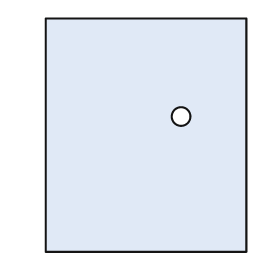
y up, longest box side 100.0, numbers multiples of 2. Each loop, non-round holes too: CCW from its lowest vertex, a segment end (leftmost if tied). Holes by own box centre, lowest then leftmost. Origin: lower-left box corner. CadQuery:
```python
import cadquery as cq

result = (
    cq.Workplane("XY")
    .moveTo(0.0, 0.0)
    .lineTo(86.0, 0.0)
    .lineTo(86.0, 100.0)
    .lineTo(0.0, 100.0)
    .close()
    .moveTo(58.0, 58.0)
    .circle(4.0)
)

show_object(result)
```